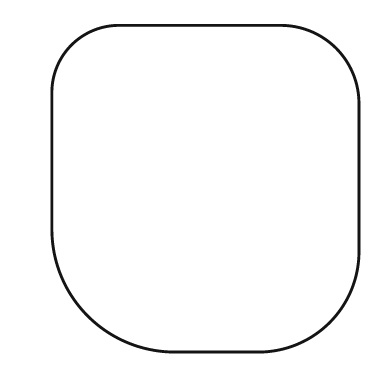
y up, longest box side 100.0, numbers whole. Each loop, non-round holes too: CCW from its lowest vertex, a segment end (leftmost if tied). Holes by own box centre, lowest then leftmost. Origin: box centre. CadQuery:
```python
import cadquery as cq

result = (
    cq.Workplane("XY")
    .moveTo(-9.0, -50.0)
    .lineTo(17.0, -50.0)
    .threePointArc((38.0, -41.0), (47.0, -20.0))
    .lineTo(47.0, 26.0)
    .threePointArc((40.0, 43.0), (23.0, 50.0))
    .lineTo(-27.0, 50.0)
    .threePointArc((-41.0, 44.0), (-47.0, 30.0))
    .lineTo(-47.0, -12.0)
    .threePointArc((-36.0, -39.0), (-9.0, -50.0))
    .close()
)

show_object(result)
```